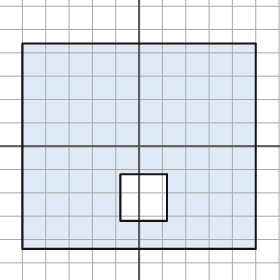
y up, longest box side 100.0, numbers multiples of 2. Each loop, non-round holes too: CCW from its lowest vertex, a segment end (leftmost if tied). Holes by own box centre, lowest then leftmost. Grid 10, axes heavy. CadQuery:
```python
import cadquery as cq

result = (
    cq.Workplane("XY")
    .moveTo(-50.0, -44.0)
    .lineTo(50.0, -44.0)
    .lineTo(50.0, 44.0)
    .lineTo(-50.0, 44.0)
    .close()
    .moveTo(-8.0, -32.0)
    .lineTo(12.0, -32.0)
    .lineTo(12.0, -12.0)
    .lineTo(-8.0, -12.0)
    .close()
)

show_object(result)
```